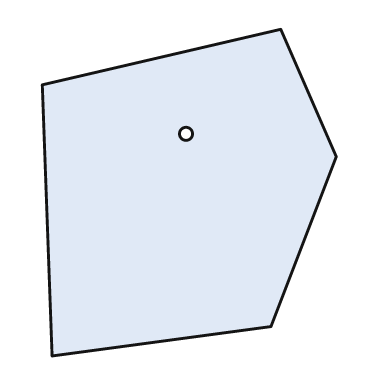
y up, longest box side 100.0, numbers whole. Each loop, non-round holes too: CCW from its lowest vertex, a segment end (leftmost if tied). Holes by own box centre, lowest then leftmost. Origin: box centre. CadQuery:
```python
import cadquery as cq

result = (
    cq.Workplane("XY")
    .moveTo(-42.0, -50.0)
    .lineTo(25.0, -41.0)
    .lineTo(45.0, 11.0)
    .lineTo(28.0, 50.0)
    .lineTo(-45.0, 33.0)
    .close()
    .moveTo(-1.0, 18.0)
    .circle(2.0)
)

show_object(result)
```